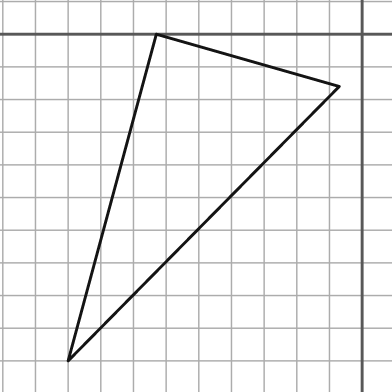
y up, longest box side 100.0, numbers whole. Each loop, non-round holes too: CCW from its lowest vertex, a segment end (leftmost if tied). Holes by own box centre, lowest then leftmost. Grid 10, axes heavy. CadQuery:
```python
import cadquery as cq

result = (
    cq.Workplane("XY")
    .moveTo(-90.0, -100.0)
    .lineTo(-7.0, -16.0)
    .lineTo(-63.0, 0.0)
    .close()
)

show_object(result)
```